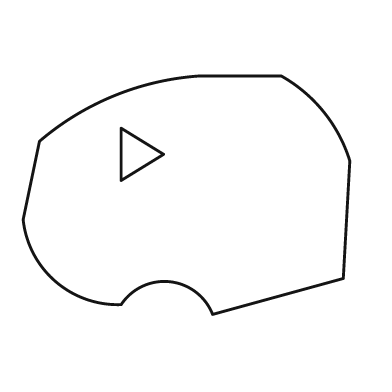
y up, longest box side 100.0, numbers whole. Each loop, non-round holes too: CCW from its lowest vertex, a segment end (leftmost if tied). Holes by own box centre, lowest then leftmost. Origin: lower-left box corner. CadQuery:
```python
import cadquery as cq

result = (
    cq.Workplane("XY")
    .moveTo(58.0, 0.0)
    .lineTo(98.0, 11.0)
    .lineTo(100.0, 47.0)
    .threePointArc((92.0, 62.0), (79.0, 73.0))
    .lineTo(54.0, 73.0)
    .threePointArc((28.0, 67.0), (5.0, 53.0))
    .lineTo(0.0, 29.0)
    .threePointArc((10.0, 10.0), (30.0, 3.0))
    .threePointArc((45.0, 10.0), (58.0, 0.0))
    .close()
    .moveTo(30.0, 41.0)
    .lineTo(43.0, 49.0)
    .lineTo(30.0, 57.0)
    .close()
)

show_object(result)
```